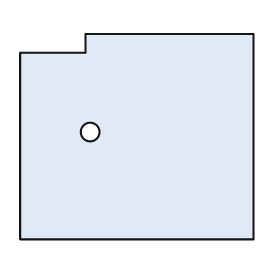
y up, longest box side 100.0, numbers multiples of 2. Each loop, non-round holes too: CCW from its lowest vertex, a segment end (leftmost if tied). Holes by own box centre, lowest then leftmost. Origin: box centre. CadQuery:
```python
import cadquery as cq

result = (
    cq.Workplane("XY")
    .moveTo(-50.0, -44.0)
    .lineTo(50.0, -44.0)
    .lineTo(50.0, 44.0)
    .lineTo(-22.0, 44.0)
    .lineTo(-22.0, 36.0)
    .lineTo(-50.0, 36.0)
    .close()
    .moveTo(-20.0, 2.0)
    .circle(4.0)
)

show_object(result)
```